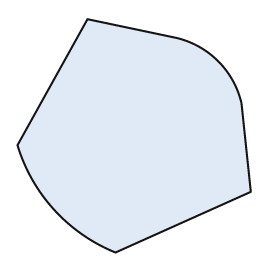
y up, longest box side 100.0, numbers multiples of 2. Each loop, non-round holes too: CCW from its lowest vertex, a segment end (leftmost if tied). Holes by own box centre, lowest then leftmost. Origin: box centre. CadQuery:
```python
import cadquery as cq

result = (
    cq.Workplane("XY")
    .moveTo(-8.0, -50.0)
    .lineTo(50.0, -24.0)
    .lineTo(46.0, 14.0)
    .threePointArc((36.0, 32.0), (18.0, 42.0))
    .lineTo(-20.0, 50.0)
    .lineTo(-50.0, -4.0)
    .threePointArc((-34.0, -32.0), (-8.0, -50.0))
    .close()
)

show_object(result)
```